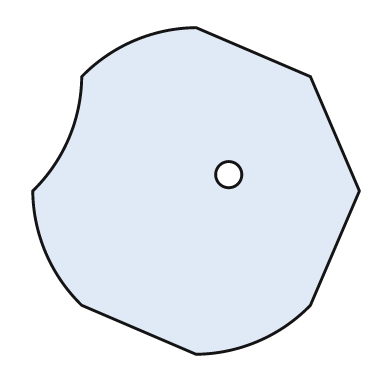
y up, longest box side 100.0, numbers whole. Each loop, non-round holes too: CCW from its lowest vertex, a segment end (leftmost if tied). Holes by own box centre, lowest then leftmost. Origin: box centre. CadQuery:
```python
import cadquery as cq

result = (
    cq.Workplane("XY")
    .moveTo(0.0, -50.0)
    .threePointArc((19.0, -46.0), (35.0, -35.0))
    .lineTo(50.0, 0.0)
    .lineTo(35.0, 35.0)
    .lineTo(0.0, 50.0)
    .threePointArc((-19.0, 46.0), (-35.0, 35.0))
    .threePointArc((-39.0, 16.0), (-50.0, 0.0))
    .threePointArc((-46.0, -19.0), (-35.0, -35.0))
    .close()
    .moveTo(10.0, 5.0)
    .circle(4.0)
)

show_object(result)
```